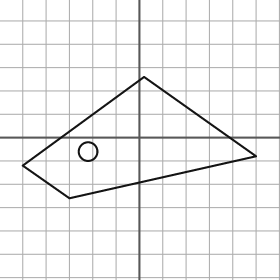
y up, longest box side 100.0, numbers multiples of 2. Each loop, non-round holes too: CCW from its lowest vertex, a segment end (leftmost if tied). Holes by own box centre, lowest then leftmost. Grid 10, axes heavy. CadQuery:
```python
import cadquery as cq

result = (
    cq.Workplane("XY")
    .moveTo(-30.0, -26.0)
    .lineTo(50.0, -8.0)
    .lineTo(2.0, 26.0)
    .lineTo(-50.0, -12.0)
    .close()
    .moveTo(-22.0, -6.0)
    .circle(4.0)
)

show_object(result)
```